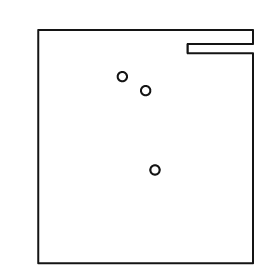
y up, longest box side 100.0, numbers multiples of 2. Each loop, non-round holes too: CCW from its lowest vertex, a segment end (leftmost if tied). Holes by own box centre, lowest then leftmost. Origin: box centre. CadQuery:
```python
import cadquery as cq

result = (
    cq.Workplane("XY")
    .moveTo(-46.0, -50.0)
    .lineTo(46.0, -50.0)
    .lineTo(46.0, 40.0)
    .lineTo(18.0, 40.0)
    .lineTo(18.0, 44.0)
    .lineTo(46.0, 44.0)
    .lineTo(46.0, 50.0)
    .lineTo(-46.0, 50.0)
    .close()
    .moveTo(4.0, -10.0)
    .circle(2.0)
    .moveTo(0.0, 24.0)
    .circle(2.0)
    .moveTo(-10.0, 30.0)
    .circle(2.0)
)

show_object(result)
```